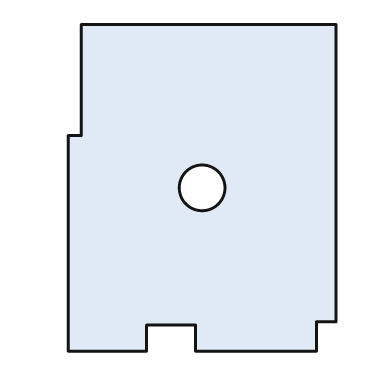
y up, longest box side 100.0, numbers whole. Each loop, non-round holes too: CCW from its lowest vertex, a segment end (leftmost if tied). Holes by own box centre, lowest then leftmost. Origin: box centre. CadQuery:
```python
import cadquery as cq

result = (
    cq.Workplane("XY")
    .moveTo(-41.0, -50.0)
    .lineTo(-17.0, -50.0)
    .lineTo(-17.0, -42.0)
    .lineTo(-2.0, -42.0)
    .lineTo(-2.0, -50.0)
    .lineTo(35.0, -50.0)
    .lineTo(35.0, -41.0)
    .lineTo(41.0, -41.0)
    .lineTo(41.0, 50.0)
    .lineTo(-37.0, 50.0)
    .lineTo(-37.0, 16.0)
    .lineTo(-41.0, 16.0)
    .close()
    .moveTo(0.0, 0.0)
    .circle(7.0)
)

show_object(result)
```